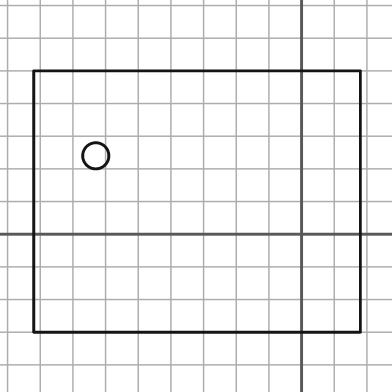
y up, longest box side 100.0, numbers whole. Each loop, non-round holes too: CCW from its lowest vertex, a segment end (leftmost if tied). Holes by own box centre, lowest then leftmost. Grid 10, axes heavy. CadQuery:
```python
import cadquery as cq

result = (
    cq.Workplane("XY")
    .moveTo(-82.0, -30.0)
    .lineTo(18.0, -30.0)
    .lineTo(18.0, 50.0)
    .lineTo(-82.0, 50.0)
    .close()
    .moveTo(-63.0, 24.0)
    .circle(4.0)
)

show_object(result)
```